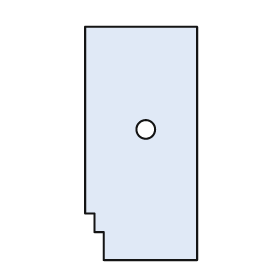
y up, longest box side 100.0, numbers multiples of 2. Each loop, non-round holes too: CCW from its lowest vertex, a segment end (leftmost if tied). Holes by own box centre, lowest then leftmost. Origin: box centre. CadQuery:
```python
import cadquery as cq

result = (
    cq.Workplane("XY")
    .moveTo(-16.0, -50.0)
    .lineTo(24.0, -50.0)
    .lineTo(24.0, 50.0)
    .lineTo(-24.0, 50.0)
    .lineTo(-24.0, -30.0)
    .lineTo(-20.0, -30.0)
    .lineTo(-20.0, -38.0)
    .lineTo(-16.0, -38.0)
    .close()
    .moveTo(2.0, 6.0)
    .circle(4.0)
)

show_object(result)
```